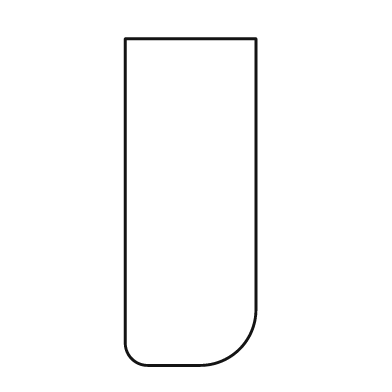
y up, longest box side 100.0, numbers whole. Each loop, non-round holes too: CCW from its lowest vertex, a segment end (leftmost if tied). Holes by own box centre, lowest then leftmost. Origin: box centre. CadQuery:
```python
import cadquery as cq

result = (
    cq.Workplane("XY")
    .moveTo(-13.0, -50.0)
    .lineTo(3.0, -50.0)
    .threePointArc((15.0, -45.0), (20.0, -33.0))
    .lineTo(20.0, 50.0)
    .lineTo(-20.0, 50.0)
    .lineTo(-20.0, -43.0)
    .threePointArc((-18.0, -48.0), (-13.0, -50.0))
    .close()
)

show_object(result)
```